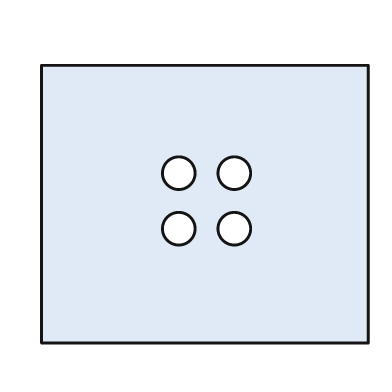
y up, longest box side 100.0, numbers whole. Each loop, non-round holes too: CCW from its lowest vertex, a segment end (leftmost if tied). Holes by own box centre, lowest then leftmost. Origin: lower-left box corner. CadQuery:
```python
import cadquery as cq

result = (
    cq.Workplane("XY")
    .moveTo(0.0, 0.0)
    .lineTo(100.0, 0.0)
    .lineTo(100.0, 85.0)
    .lineTo(0.0, 85.0)
    .close()
    .moveTo(42.0, 35.0)
    .circle(5.0)
    .moveTo(59.0, 35.0)
    .circle(5.0)
    .moveTo(42.0, 52.0)
    .circle(5.0)
    .moveTo(59.0, 52.0)
    .circle(5.0)
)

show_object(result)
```